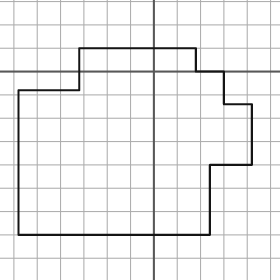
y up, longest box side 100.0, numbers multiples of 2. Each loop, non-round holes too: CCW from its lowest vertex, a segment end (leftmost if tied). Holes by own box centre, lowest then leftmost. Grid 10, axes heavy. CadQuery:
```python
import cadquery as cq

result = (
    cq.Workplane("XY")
    .moveTo(-58.0, -70.0)
    .lineTo(24.0, -70.0)
    .lineTo(24.0, -40.0)
    .lineTo(42.0, -40.0)
    .lineTo(42.0, -14.0)
    .lineTo(30.0, -14.0)
    .lineTo(30.0, 0.0)
    .lineTo(18.0, 0.0)
    .lineTo(18.0, 10.0)
    .lineTo(-32.0, 10.0)
    .lineTo(-32.0, -8.0)
    .lineTo(-58.0, -8.0)
    .close()
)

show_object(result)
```